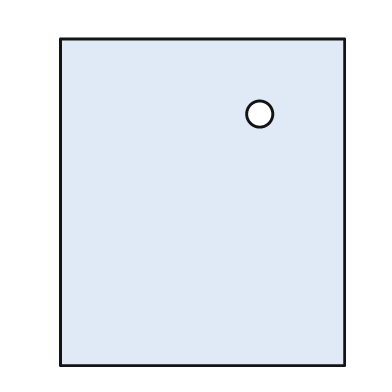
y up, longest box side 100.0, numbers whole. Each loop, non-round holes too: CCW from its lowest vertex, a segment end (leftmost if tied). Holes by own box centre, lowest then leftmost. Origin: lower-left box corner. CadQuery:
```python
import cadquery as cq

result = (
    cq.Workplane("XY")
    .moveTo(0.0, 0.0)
    .lineTo(87.0, 0.0)
    .lineTo(87.0, 100.0)
    .lineTo(0.0, 100.0)
    .close()
    .moveTo(61.0, 77.0)
    .circle(4.0)
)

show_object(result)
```